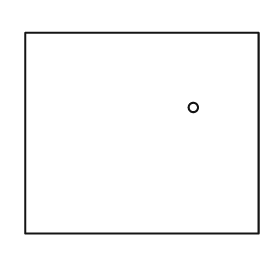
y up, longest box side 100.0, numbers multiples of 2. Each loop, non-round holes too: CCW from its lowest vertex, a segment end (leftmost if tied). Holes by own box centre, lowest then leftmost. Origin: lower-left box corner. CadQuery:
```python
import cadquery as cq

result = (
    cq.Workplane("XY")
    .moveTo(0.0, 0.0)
    .lineTo(100.0, 0.0)
    .lineTo(100.0, 86.0)
    .lineTo(0.0, 86.0)
    .close()
    .moveTo(72.0, 54.0)
    .circle(2.0)
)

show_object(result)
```